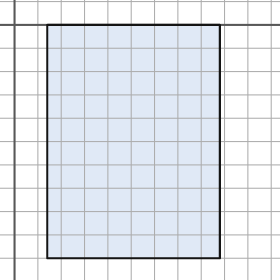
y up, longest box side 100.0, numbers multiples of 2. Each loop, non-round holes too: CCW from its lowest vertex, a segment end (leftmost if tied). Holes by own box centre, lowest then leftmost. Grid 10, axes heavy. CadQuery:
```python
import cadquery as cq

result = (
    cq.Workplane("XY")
    .moveTo(14.0, -100.0)
    .lineTo(88.0, -100.0)
    .lineTo(88.0, 0.0)
    .lineTo(14.0, 0.0)
    .close()
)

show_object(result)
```